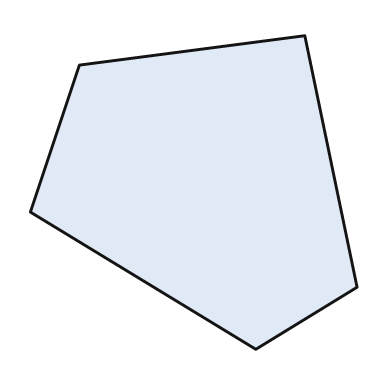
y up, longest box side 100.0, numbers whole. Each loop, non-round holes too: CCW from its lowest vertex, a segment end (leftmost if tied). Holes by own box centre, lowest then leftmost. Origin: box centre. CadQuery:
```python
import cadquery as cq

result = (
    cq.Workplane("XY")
    .moveTo(19.0, -48.0)
    .lineTo(50.0, -29.0)
    .lineTo(34.0, 48.0)
    .lineTo(-35.0, 39.0)
    .lineTo(-50.0, -6.0)
    .close()
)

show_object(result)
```